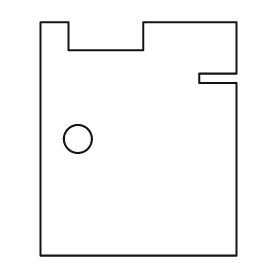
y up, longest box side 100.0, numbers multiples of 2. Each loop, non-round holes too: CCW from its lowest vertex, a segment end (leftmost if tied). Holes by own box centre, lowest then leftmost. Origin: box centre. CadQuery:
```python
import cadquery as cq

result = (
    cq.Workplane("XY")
    .moveTo(-42.0, -50.0)
    .lineTo(42.0, -50.0)
    .lineTo(42.0, 24.0)
    .lineTo(26.0, 24.0)
    .lineTo(26.0, 28.0)
    .lineTo(42.0, 28.0)
    .lineTo(42.0, 50.0)
    .lineTo(2.0, 50.0)
    .lineTo(2.0, 38.0)
    .lineTo(-30.0, 38.0)
    .lineTo(-30.0, 50.0)
    .lineTo(-42.0, 50.0)
    .close()
    .moveTo(-26.0, 0.0)
    .circle(6.0)
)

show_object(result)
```